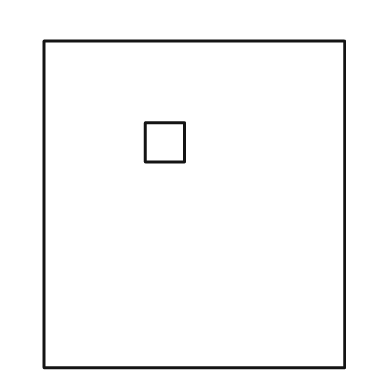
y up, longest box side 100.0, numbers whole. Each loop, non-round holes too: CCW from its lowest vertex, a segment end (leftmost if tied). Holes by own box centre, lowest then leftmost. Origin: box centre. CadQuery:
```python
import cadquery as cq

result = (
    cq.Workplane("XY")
    .moveTo(-46.0, -50.0)
    .lineTo(46.0, -50.0)
    .lineTo(46.0, 50.0)
    .lineTo(-46.0, 50.0)
    .close()
    .moveTo(-15.0, 13.0)
    .lineTo(-3.0, 13.0)
    .lineTo(-3.0, 25.0)
    .lineTo(-15.0, 25.0)
    .close()
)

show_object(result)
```